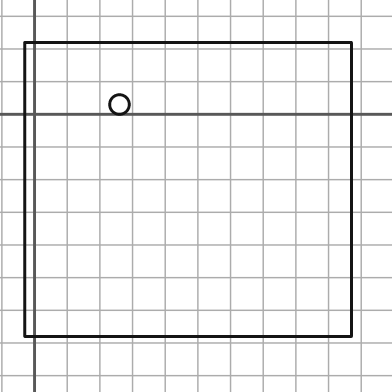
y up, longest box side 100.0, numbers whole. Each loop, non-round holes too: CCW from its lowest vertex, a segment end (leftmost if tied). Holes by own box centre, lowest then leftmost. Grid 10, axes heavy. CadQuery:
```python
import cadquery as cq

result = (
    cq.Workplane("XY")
    .moveTo(-3.0, -68.0)
    .lineTo(97.0, -68.0)
    .lineTo(97.0, 22.0)
    .lineTo(-3.0, 22.0)
    .close()
    .moveTo(26.0, 3.0)
    .circle(3.0)
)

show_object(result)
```